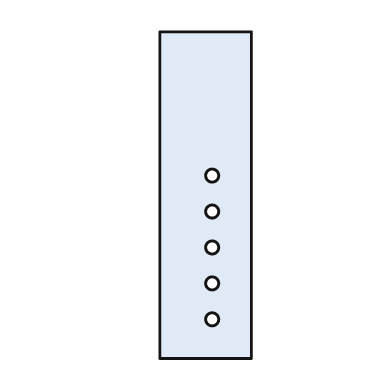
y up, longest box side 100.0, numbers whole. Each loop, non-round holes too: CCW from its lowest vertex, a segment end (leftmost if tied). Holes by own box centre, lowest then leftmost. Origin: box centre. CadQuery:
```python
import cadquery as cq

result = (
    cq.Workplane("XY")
    .moveTo(-14.0, -50.0)
    .lineTo(14.0, -50.0)
    .lineTo(14.0, 50.0)
    .lineTo(-14.0, 50.0)
    .close()
    .moveTo(2.0, -38.0)
    .circle(2.0)
    .moveTo(2.0, -27.0)
    .circle(2.0)
    .moveTo(2.0, -16.0)
    .circle(2.0)
    .moveTo(2.0, -5.0)
    .circle(2.0)
    .moveTo(2.0, 6.0)
    .circle(2.0)
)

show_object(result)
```